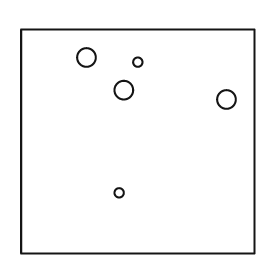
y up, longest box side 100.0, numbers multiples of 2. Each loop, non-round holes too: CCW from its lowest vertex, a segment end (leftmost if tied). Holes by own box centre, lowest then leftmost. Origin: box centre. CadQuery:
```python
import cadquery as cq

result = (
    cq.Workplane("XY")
    .moveTo(-50.0, -48.0)
    .lineTo(50.0, -48.0)
    .lineTo(50.0, 48.0)
    .lineTo(-50.0, 48.0)
    .close()
    .moveTo(-8.0, -22.0)
    .circle(2.0)
    .moveTo(38.0, 18.0)
    .circle(4.0)
    .moveTo(-6.0, 22.0)
    .circle(4.0)
    .moveTo(0.0, 34.0)
    .circle(2.0)
    .moveTo(-22.0, 36.0)
    .circle(4.0)
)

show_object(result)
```